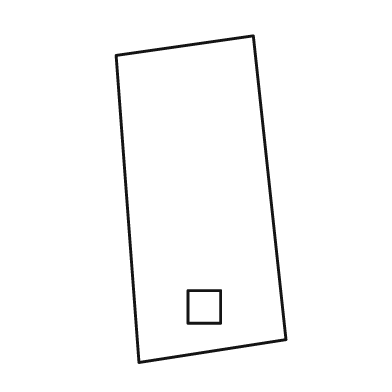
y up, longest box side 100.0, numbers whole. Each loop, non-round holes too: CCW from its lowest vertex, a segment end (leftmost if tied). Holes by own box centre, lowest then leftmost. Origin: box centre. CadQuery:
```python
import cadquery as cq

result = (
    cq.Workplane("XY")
    .moveTo(-19.0, -50.0)
    .lineTo(26.0, -43.0)
    .lineTo(16.0, 50.0)
    .lineTo(-26.0, 44.0)
    .close()
    .moveTo(-4.0, -38.0)
    .lineTo(6.0, -38.0)
    .lineTo(6.0, -28.0)
    .lineTo(-4.0, -28.0)
    .close()
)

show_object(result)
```